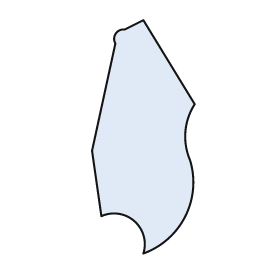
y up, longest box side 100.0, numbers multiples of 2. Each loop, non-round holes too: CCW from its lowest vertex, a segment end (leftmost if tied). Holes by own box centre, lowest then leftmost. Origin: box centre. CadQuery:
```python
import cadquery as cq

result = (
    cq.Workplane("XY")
    .moveTo(0.0, -50.0)
    .threePointArc((18.0, -34.0), (20.0, -10.0))
    .threePointArc((18.0, 2.0), (22.0, 14.0))
    .lineTo(0.0, 50.0)
    .lineTo(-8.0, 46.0)
    .threePointArc((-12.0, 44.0), (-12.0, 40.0))
    .lineTo(-22.0, -6.0)
    .lineTo(-18.0, -34.0)
    .threePointArc((-4.0, -36.0), (0.0, -50.0))
    .close()
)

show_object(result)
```